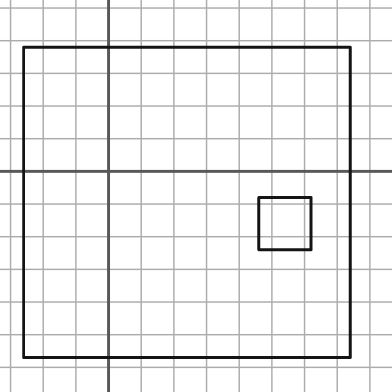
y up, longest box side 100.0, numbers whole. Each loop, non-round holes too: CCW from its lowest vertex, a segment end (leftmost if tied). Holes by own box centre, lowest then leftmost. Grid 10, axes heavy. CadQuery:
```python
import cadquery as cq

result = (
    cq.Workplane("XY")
    .moveTo(-26.0, -57.0)
    .lineTo(74.0, -57.0)
    .lineTo(74.0, 38.0)
    .lineTo(-26.0, 38.0)
    .close()
    .moveTo(46.0, -24.0)
    .lineTo(62.0, -24.0)
    .lineTo(62.0, -8.0)
    .lineTo(46.0, -8.0)
    .close()
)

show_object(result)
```